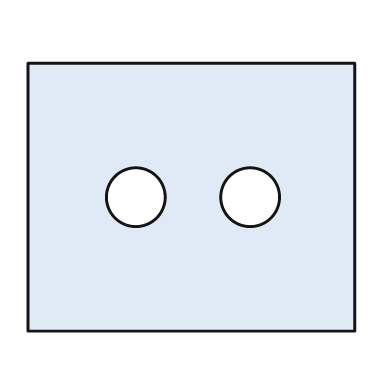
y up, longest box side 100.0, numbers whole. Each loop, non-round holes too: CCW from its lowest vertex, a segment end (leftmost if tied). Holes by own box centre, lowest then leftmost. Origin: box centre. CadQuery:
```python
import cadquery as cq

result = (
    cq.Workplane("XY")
    .moveTo(-50.0, -41.0)
    .lineTo(50.0, -41.0)
    .lineTo(50.0, 41.0)
    .lineTo(-50.0, 41.0)
    .close()
    .moveTo(-17.0, 0.0)
    .circle(9.0)
    .moveTo(18.0, 0.0)
    .circle(9.0)
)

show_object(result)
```